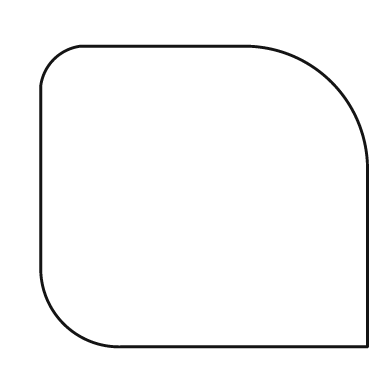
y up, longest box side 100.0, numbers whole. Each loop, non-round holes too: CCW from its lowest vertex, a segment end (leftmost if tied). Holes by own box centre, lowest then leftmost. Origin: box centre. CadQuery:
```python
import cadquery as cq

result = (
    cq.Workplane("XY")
    .moveTo(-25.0, -46.0)
    .lineTo(50.0, -46.0)
    .lineTo(50.0, 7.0)
    .threePointArc((39.0, 35.0), (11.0, 46.0))
    .lineTo(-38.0, 46.0)
    .threePointArc((-46.0, 42.0), (-50.0, 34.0))
    .lineTo(-50.0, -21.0)
    .threePointArc((-43.0, -39.0), (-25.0, -46.0))
    .close()
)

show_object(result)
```